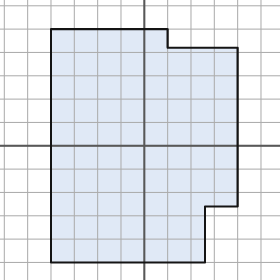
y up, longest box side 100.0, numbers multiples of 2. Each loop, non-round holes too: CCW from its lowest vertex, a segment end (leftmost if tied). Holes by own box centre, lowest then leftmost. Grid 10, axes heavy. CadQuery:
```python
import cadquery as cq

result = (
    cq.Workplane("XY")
    .moveTo(-40.0, -50.0)
    .lineTo(26.0, -50.0)
    .lineTo(26.0, -26.0)
    .lineTo(40.0, -26.0)
    .lineTo(40.0, 42.0)
    .lineTo(10.0, 42.0)
    .lineTo(10.0, 50.0)
    .lineTo(-40.0, 50.0)
    .close()
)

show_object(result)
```